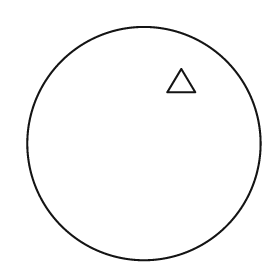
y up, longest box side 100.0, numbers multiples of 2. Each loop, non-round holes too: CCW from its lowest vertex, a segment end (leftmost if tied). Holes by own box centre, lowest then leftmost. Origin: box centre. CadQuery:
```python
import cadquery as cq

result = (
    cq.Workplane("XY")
    .moveTo(0.0, 0.0)
    .circle(50.0)
    .moveTo(10.0, 22.0)
    .lineTo(22.0, 22.0)
    .lineTo(16.0, 32.0)
    .close()
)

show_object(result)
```